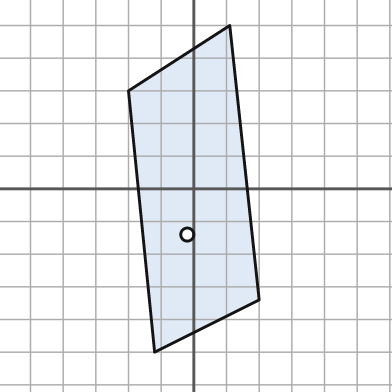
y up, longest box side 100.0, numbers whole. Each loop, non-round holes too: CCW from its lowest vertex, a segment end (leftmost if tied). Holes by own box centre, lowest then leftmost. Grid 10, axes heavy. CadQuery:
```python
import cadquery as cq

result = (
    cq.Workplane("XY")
    .moveTo(-12.0, -50.0)
    .lineTo(20.0, -34.0)
    .lineTo(11.0, 50.0)
    .lineTo(-20.0, 30.0)
    .close()
    .moveTo(-2.0, -14.0)
    .circle(2.0)
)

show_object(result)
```